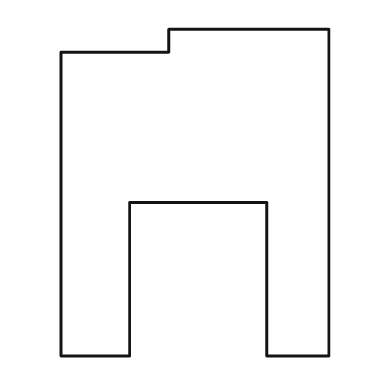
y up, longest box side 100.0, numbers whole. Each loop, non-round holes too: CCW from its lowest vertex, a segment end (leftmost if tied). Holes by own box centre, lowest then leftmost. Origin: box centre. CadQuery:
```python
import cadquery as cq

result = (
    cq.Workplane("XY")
    .moveTo(-41.0, -50.0)
    .lineTo(-20.0, -50.0)
    .lineTo(-20.0, -3.0)
    .lineTo(22.0, -3.0)
    .lineTo(22.0, -50.0)
    .lineTo(41.0, -50.0)
    .lineTo(41.0, 50.0)
    .lineTo(-8.0, 50.0)
    .lineTo(-8.0, 43.0)
    .lineTo(-41.0, 43.0)
    .close()
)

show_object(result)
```